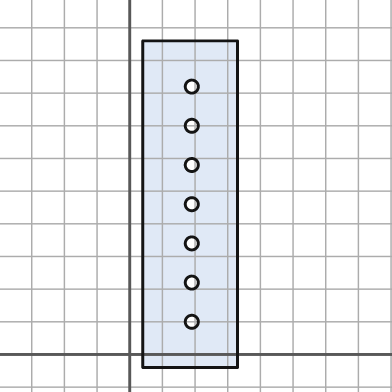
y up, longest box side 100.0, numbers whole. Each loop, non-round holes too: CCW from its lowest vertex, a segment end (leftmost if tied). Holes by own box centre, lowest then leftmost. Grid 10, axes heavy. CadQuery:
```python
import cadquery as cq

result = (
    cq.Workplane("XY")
    .moveTo(4.0, -4.0)
    .lineTo(33.0, -4.0)
    .lineTo(33.0, 96.0)
    .lineTo(4.0, 96.0)
    .close()
    .moveTo(19.0, 10.0)
    .circle(2.0)
    .moveTo(19.0, 22.0)
    .circle(2.0)
    .moveTo(19.0, 34.0)
    .circle(2.0)
    .moveTo(19.0, 46.0)
    .circle(2.0)
    .moveTo(19.0, 58.0)
    .circle(2.0)
    .moveTo(19.0, 70.0)
    .circle(2.0)
    .moveTo(19.0, 82.0)
    .circle(2.0)
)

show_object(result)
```